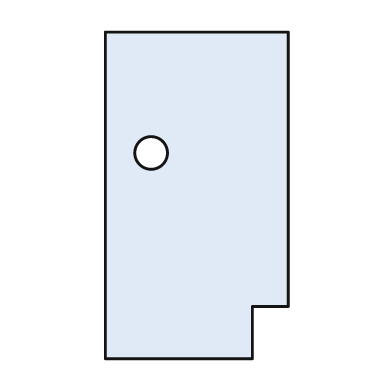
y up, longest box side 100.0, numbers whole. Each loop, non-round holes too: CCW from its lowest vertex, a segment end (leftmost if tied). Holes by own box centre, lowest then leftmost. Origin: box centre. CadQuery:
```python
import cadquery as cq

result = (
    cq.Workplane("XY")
    .moveTo(-28.0, -50.0)
    .lineTo(17.0, -50.0)
    .lineTo(17.0, -34.0)
    .lineTo(28.0, -34.0)
    .lineTo(28.0, 50.0)
    .lineTo(-28.0, 50.0)
    .close()
    .moveTo(-14.0, 13.0)
    .circle(5.0)
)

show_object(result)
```